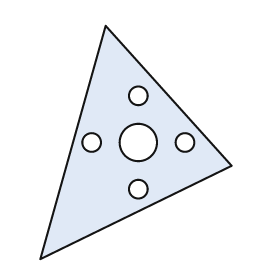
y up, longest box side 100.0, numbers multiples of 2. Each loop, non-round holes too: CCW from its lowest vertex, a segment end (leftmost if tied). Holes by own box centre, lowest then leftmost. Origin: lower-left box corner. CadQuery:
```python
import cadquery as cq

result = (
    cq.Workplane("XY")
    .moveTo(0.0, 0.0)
    .lineTo(82.0, 40.0)
    .lineTo(28.0, 100.0)
    .close()
    .moveTo(42.0, 30.0)
    .circle(4.0)
    .moveTo(22.0, 50.0)
    .circle(4.0)
    .moveTo(42.0, 50.0)
    .circle(8.0)
    .moveTo(62.0, 50.0)
    .circle(4.0)
    .moveTo(42.0, 70.0)
    .circle(4.0)
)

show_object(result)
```